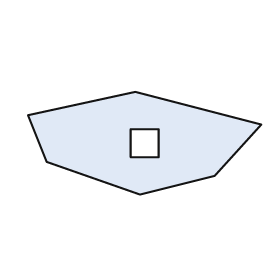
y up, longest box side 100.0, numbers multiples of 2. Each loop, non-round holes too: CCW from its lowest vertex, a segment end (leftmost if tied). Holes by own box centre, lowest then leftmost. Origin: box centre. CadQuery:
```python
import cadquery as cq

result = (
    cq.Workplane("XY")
    .moveTo(-2.0, -22.0)
    .lineTo(30.0, -14.0)
    .lineTo(50.0, 8.0)
    .lineTo(-4.0, 22.0)
    .lineTo(-50.0, 12.0)
    .lineTo(-42.0, -8.0)
    .close()
    .moveTo(-6.0, -6.0)
    .lineTo(6.0, -6.0)
    .lineTo(6.0, 6.0)
    .lineTo(-6.0, 6.0)
    .close()
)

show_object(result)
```